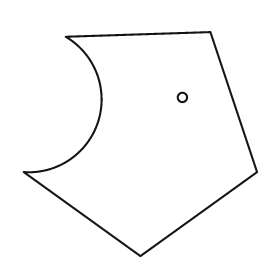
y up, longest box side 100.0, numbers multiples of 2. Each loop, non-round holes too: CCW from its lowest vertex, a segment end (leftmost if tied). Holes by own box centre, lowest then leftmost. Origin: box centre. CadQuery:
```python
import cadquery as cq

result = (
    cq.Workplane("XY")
    .moveTo(0.0, -48.0)
    .lineTo(50.0, -12.0)
    .lineTo(30.0, 48.0)
    .lineTo(-32.0, 46.0)
    .threePointArc((-18.0, 10.0), (-50.0, -12.0))
    .close()
    .moveTo(18.0, 20.0)
    .circle(2.0)
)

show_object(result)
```